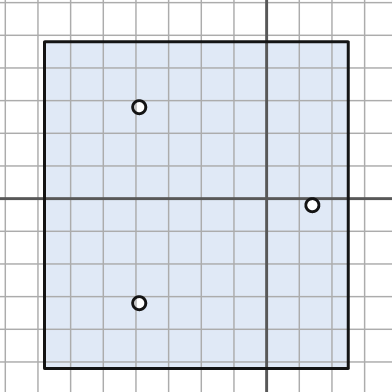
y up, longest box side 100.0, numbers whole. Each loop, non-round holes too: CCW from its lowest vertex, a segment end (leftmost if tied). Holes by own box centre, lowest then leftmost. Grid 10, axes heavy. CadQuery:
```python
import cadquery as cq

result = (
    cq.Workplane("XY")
    .moveTo(-68.0, -52.0)
    .lineTo(25.0, -52.0)
    .lineTo(25.0, 48.0)
    .lineTo(-68.0, 48.0)
    .close()
    .moveTo(-39.0, -32.0)
    .circle(2.0)
    .moveTo(14.0, -2.0)
    .circle(2.0)
    .moveTo(-39.0, 28.0)
    .circle(2.0)
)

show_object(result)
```